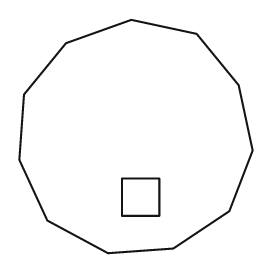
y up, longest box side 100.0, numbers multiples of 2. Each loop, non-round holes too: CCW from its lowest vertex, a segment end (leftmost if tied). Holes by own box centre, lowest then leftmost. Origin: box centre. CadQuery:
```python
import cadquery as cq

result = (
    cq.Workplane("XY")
    .moveTo(-12.0, -50.0)
    .lineTo(16.0, -48.0)
    .lineTo(40.0, -32.0)
    .lineTo(50.0, -6.0)
    .lineTo(44.0, 22.0)
    .lineTo(26.0, 44.0)
    .lineTo(-2.0, 50.0)
    .lineTo(-30.0, 40.0)
    .lineTo(-48.0, 18.0)
    .lineTo(-50.0, -10.0)
    .lineTo(-38.0, -36.0)
    .close()
    .moveTo(-6.0, -34.0)
    .lineTo(10.0, -34.0)
    .lineTo(10.0, -18.0)
    .lineTo(-6.0, -18.0)
    .close()
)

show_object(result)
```